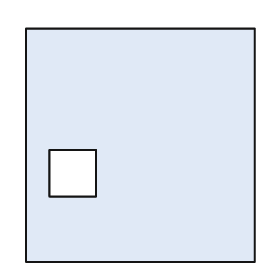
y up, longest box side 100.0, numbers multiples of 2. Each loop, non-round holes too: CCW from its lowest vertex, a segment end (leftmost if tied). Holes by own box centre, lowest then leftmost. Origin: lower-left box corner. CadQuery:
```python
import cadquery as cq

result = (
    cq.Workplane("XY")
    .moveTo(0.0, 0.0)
    .lineTo(98.0, 0.0)
    .lineTo(98.0, 100.0)
    .lineTo(0.0, 100.0)
    .close()
    .moveTo(10.0, 28.0)
    .lineTo(30.0, 28.0)
    .lineTo(30.0, 48.0)
    .lineTo(10.0, 48.0)
    .close()
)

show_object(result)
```